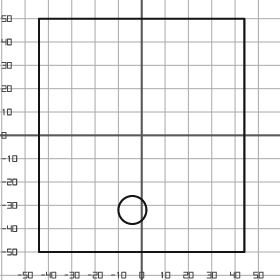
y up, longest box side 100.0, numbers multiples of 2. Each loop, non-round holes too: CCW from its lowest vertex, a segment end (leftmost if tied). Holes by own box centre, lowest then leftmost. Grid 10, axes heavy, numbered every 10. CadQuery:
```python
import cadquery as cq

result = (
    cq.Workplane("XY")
    .moveTo(-44.0, -50.0)
    .lineTo(44.0, -50.0)
    .lineTo(44.0, 50.0)
    .lineTo(-44.0, 50.0)
    .close()
    .moveTo(-4.0, -32.0)
    .circle(6.0)
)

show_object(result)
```